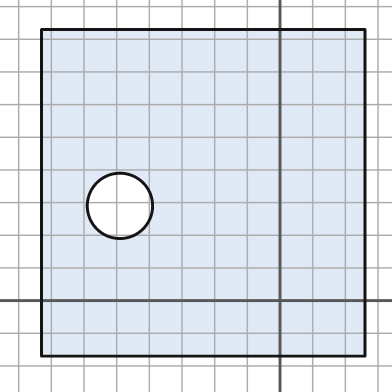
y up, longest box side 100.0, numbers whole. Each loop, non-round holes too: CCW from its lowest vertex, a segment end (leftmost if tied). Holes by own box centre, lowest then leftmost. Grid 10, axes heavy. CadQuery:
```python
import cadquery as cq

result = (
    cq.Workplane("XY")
    .moveTo(-73.0, -17.0)
    .lineTo(26.0, -17.0)
    .lineTo(26.0, 83.0)
    .lineTo(-73.0, 83.0)
    .close()
    .moveTo(-49.0, 29.0)
    .circle(10.0)
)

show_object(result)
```